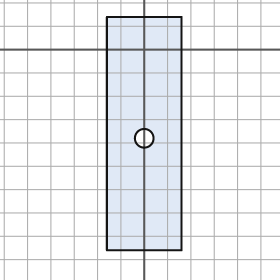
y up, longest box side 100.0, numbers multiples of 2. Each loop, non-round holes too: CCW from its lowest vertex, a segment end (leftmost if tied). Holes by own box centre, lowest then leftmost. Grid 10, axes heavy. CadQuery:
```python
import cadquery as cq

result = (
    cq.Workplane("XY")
    .moveTo(-16.0, -86.0)
    .lineTo(16.0, -86.0)
    .lineTo(16.0, 14.0)
    .lineTo(-16.0, 14.0)
    .close()
    .moveTo(0.0, -38.0)
    .circle(4.0)
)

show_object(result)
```